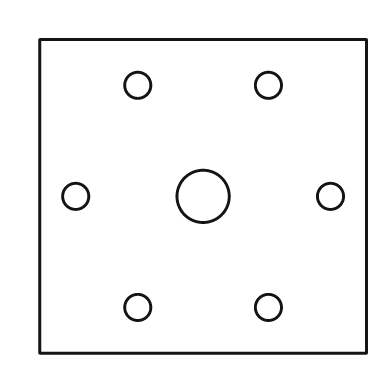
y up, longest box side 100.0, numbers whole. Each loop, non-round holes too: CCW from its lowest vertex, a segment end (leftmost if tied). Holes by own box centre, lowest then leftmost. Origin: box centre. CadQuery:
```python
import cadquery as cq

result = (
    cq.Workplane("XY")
    .moveTo(-50.0, -48.0)
    .lineTo(50.0, -48.0)
    .lineTo(50.0, 48.0)
    .lineTo(-50.0, 48.0)
    .close()
    .moveTo(-20.0, -34.0)
    .circle(4.0)
    .moveTo(20.0, -34.0)
    .circle(4.0)
    .moveTo(-39.0, 0.0)
    .circle(4.0)
    .moveTo(0.0, 0.0)
    .circle(8.0)
    .moveTo(39.0, 0.0)
    .circle(4.0)
    .moveTo(-20.0, 34.0)
    .circle(4.0)
    .moveTo(20.0, 34.0)
    .circle(4.0)
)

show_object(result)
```